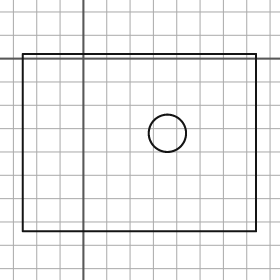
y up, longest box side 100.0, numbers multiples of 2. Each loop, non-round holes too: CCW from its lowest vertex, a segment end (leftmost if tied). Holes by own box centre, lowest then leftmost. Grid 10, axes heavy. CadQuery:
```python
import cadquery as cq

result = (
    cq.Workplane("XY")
    .moveTo(-26.0, -74.0)
    .lineTo(74.0, -74.0)
    .lineTo(74.0, 2.0)
    .lineTo(-26.0, 2.0)
    .close()
    .moveTo(36.0, -32.0)
    .circle(8.0)
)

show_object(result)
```